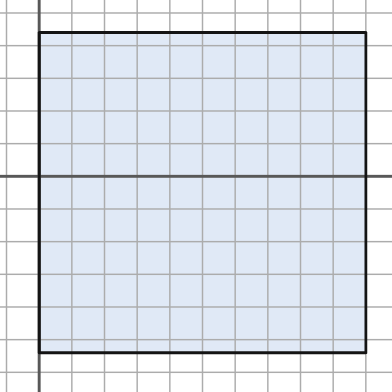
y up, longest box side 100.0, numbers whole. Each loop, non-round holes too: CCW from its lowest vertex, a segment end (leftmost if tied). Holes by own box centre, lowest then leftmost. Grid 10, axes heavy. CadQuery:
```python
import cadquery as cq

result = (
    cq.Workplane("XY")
    .moveTo(0.0, -54.0)
    .lineTo(100.0, -54.0)
    .lineTo(100.0, 44.0)
    .lineTo(0.0, 44.0)
    .close()
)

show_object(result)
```